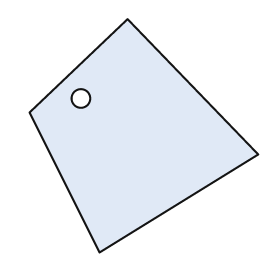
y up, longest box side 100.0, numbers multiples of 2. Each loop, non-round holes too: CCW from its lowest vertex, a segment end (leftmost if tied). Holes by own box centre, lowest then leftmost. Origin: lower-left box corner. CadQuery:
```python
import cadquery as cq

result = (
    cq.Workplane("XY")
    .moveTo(30.0, 0.0)
    .lineTo(98.0, 42.0)
    .lineTo(42.0, 100.0)
    .lineTo(0.0, 60.0)
    .close()
    .moveTo(22.0, 66.0)
    .circle(4.0)
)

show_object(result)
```